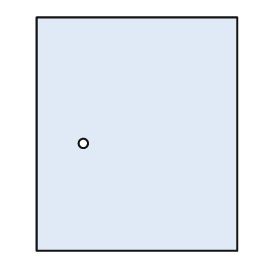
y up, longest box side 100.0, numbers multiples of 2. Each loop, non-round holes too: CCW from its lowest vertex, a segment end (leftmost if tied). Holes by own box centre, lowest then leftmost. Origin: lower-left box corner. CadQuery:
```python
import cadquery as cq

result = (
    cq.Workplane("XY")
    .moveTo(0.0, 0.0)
    .lineTo(86.0, 0.0)
    .lineTo(86.0, 100.0)
    .lineTo(0.0, 100.0)
    .close()
    .moveTo(20.0, 46.0)
    .circle(2.0)
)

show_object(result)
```